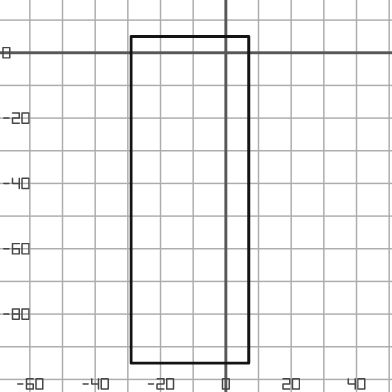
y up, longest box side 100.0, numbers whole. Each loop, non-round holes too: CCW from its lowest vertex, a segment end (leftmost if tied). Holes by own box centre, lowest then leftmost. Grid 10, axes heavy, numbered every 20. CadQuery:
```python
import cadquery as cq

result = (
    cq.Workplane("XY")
    .moveTo(-29.0, -95.0)
    .lineTo(7.0, -95.0)
    .lineTo(7.0, 5.0)
    .lineTo(-29.0, 5.0)
    .close()
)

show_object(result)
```